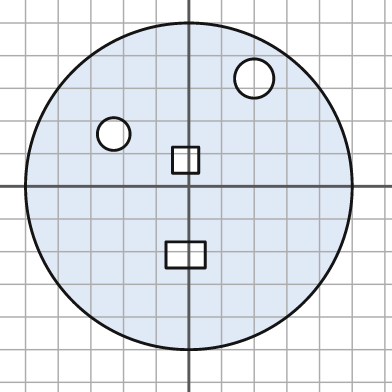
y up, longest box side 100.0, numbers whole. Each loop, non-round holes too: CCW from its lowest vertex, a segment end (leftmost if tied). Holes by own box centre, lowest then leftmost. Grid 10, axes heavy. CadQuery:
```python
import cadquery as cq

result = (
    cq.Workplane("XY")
    .moveTo(0.0, 0.0)
    .circle(50.0)
    .moveTo(-7.0, -25.0)
    .lineTo(5.0, -25.0)
    .lineTo(5.0, -17.0)
    .lineTo(-7.0, -17.0)
    .close()
    .moveTo(-5.0, 4.0)
    .lineTo(3.0, 4.0)
    .lineTo(3.0, 12.0)
    .lineTo(-5.0, 12.0)
    .close()
    .moveTo(-23.0, 16.0)
    .circle(5.0)
    .moveTo(20.0, 33.0)
    .circle(6.0)
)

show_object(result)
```